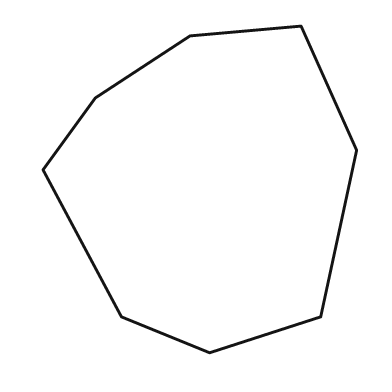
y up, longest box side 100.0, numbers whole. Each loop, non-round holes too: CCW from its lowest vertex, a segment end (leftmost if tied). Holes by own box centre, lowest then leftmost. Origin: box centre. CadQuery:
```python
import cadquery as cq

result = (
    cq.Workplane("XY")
    .moveTo(3.0, -50.0)
    .lineTo(37.0, -39.0)
    .lineTo(48.0, 12.0)
    .lineTo(31.0, 50.0)
    .lineTo(-3.0, 47.0)
    .lineTo(-32.0, 28.0)
    .lineTo(-48.0, 6.0)
    .lineTo(-24.0, -39.0)
    .close()
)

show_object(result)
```